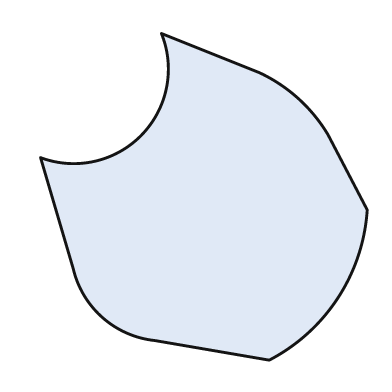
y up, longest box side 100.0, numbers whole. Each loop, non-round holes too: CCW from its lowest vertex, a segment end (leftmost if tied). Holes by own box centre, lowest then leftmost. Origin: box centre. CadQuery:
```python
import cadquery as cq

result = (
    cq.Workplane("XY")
    .moveTo(20.0, -50.0)
    .threePointArc((41.0, -31.0), (50.0, -4.0))
    .lineTo(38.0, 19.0)
    .threePointArc((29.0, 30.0), (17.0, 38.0))
    .lineTo(-13.0, 50.0)
    .threePointArc((-19.0, 19.0), (-50.0, 12.0))
    .lineTo(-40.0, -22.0)
    .threePointArc((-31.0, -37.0), (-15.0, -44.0))
    .close()
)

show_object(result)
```